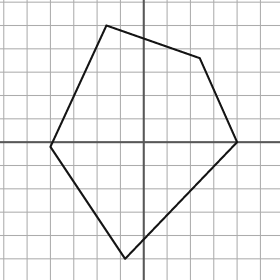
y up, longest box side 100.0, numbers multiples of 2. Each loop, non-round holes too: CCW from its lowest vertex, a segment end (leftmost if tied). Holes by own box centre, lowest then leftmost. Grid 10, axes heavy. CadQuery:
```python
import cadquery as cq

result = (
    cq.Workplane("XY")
    .moveTo(-8.0, -50.0)
    .lineTo(40.0, 0.0)
    .lineTo(24.0, 36.0)
    .lineTo(-16.0, 50.0)
    .lineTo(-40.0, -2.0)
    .close()
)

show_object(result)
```